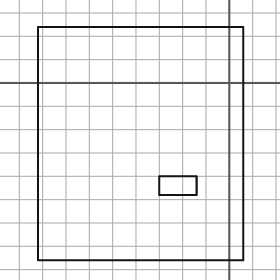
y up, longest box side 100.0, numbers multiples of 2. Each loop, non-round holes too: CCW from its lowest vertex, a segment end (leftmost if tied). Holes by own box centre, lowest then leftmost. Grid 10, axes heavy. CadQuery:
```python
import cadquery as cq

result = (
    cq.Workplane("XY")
    .moveTo(-82.0, -76.0)
    .lineTo(6.0, -76.0)
    .lineTo(6.0, 24.0)
    .lineTo(-82.0, 24.0)
    .close()
    .moveTo(-30.0, -48.0)
    .lineTo(-14.0, -48.0)
    .lineTo(-14.0, -40.0)
    .lineTo(-30.0, -40.0)
    .close()
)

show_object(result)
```